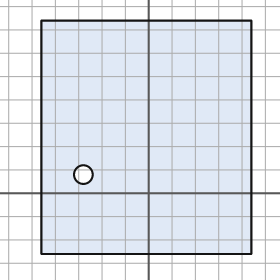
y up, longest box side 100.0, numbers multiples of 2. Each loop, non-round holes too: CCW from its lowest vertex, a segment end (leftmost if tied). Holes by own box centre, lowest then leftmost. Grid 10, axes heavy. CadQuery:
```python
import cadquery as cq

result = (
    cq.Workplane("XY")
    .moveTo(-46.0, -26.0)
    .lineTo(44.0, -26.0)
    .lineTo(44.0, 74.0)
    .lineTo(-46.0, 74.0)
    .close()
    .moveTo(-28.0, 8.0)
    .circle(4.0)
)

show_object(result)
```